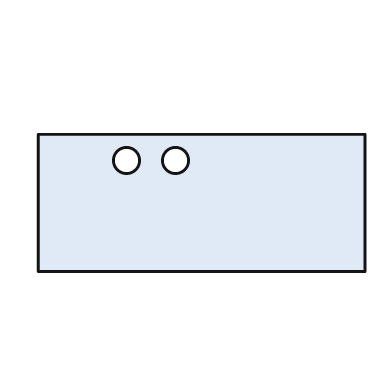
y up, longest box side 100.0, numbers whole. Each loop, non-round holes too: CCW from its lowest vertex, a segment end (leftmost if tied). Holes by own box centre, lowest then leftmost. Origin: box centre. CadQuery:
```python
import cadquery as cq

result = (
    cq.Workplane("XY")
    .moveTo(-50.0, -21.0)
    .lineTo(50.0, -21.0)
    .lineTo(50.0, 21.0)
    .lineTo(-50.0, 21.0)
    .close()
    .moveTo(-23.0, 13.0)
    .circle(4.0)
    .moveTo(-8.0, 13.0)
    .circle(4.0)
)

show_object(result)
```